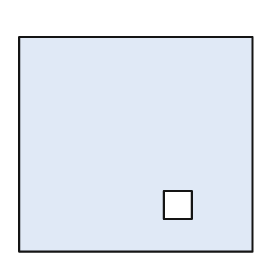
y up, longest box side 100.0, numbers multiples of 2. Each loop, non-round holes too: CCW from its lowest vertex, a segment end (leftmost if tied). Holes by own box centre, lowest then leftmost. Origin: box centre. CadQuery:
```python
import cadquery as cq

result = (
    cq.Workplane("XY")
    .moveTo(-50.0, -46.0)
    .lineTo(50.0, -46.0)
    .lineTo(50.0, 46.0)
    .lineTo(-50.0, 46.0)
    .close()
    .moveTo(12.0, -32.0)
    .lineTo(24.0, -32.0)
    .lineTo(24.0, -20.0)
    .lineTo(12.0, -20.0)
    .close()
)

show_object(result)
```